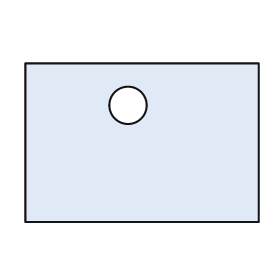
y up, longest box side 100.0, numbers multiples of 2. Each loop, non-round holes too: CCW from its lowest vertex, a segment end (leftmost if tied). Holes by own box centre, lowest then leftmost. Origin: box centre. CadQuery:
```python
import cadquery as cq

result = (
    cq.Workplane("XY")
    .moveTo(-50.0, -34.0)
    .lineTo(50.0, -34.0)
    .lineTo(50.0, 34.0)
    .lineTo(-50.0, 34.0)
    .close()
    .moveTo(-6.0, 16.0)
    .circle(8.0)
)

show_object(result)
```